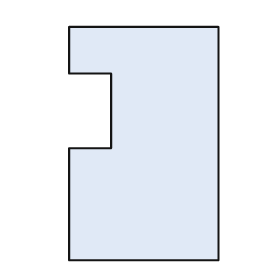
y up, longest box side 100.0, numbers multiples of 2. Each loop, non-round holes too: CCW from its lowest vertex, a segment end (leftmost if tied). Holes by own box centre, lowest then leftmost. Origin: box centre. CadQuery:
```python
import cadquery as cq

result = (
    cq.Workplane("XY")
    .moveTo(-32.0, -50.0)
    .lineTo(32.0, -50.0)
    .lineTo(32.0, 50.0)
    .lineTo(-32.0, 50.0)
    .lineTo(-32.0, 30.0)
    .lineTo(-14.0, 30.0)
    .lineTo(-14.0, -2.0)
    .lineTo(-32.0, -2.0)
    .close()
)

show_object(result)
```